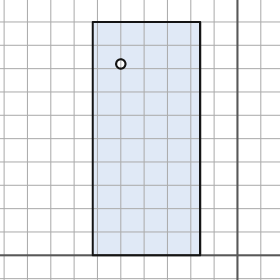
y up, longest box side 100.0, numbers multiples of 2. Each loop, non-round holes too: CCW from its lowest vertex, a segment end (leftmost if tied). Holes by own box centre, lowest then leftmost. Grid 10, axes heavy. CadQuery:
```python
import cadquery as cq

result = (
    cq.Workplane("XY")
    .moveTo(-62.0, 0.0)
    .lineTo(-16.0, 0.0)
    .lineTo(-16.0, 100.0)
    .lineTo(-62.0, 100.0)
    .close()
    .moveTo(-50.0, 82.0)
    .circle(2.0)
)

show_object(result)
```